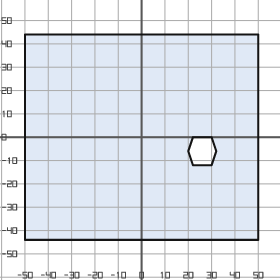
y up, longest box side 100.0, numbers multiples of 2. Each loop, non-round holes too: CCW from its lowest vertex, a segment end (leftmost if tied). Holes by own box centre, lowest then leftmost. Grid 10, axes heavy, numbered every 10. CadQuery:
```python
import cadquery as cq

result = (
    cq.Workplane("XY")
    .moveTo(-50.0, -44.0)
    .lineTo(50.0, -44.0)
    .lineTo(50.0, 44.0)
    .lineTo(-50.0, 44.0)
    .close()
    .moveTo(22.0, -12.0)
    .lineTo(30.0, -12.0)
    .lineTo(32.0, -6.0)
    .lineTo(30.0, 0.0)
    .lineTo(22.0, 0.0)
    .lineTo(20.0, -6.0)
    .close()
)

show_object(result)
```